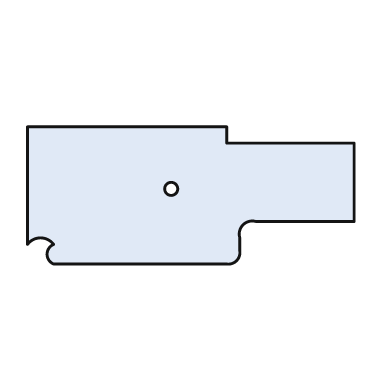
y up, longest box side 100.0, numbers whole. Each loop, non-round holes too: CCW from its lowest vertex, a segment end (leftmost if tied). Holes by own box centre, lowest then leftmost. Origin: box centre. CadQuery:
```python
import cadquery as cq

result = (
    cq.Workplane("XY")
    .moveTo(-42.0, -21.0)
    .lineTo(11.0, -21.0)
    .threePointArc((14.0, -20.0), (15.0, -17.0))
    .lineTo(15.0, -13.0)
    .threePointArc((16.0, -9.0), (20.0, -8.0))
    .lineTo(50.0, -8.0)
    .lineTo(50.0, 16.0)
    .lineTo(11.0, 16.0)
    .lineTo(11.0, 21.0)
    .lineTo(-50.0, 21.0)
    .lineTo(-50.0, -15.0)
    .threePointArc((-46.0, -13.0), (-42.0, -15.0))
    .threePointArc((-44.0, -18.0), (-42.0, -21.0))
    .close()
    .moveTo(-6.0, 2.0)
    .circle(2.0)
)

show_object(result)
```